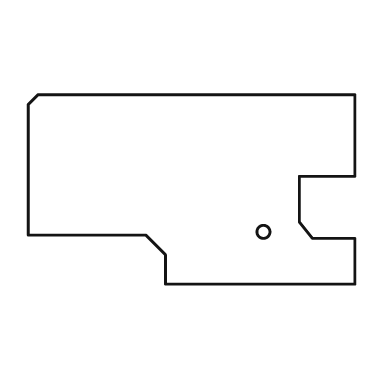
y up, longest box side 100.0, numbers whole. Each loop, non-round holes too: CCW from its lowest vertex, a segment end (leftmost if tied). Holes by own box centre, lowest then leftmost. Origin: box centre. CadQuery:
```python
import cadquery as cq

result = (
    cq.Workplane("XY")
    .moveTo(-8.0, -29.0)
    .lineTo(50.0, -29.0)
    .lineTo(50.0, -15.0)
    .lineTo(37.0, -15.0)
    .lineTo(33.0, -10.0)
    .lineTo(33.0, 4.0)
    .lineTo(50.0, 4.0)
    .lineTo(50.0, 29.0)
    .lineTo(-47.0, 29.0)
    .lineTo(-50.0, 26.0)
    .lineTo(-50.0, -14.0)
    .lineTo(-14.0, -14.0)
    .lineTo(-8.0, -20.0)
    .close()
    .moveTo(22.0, -13.0)
    .circle(2.0)
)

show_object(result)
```